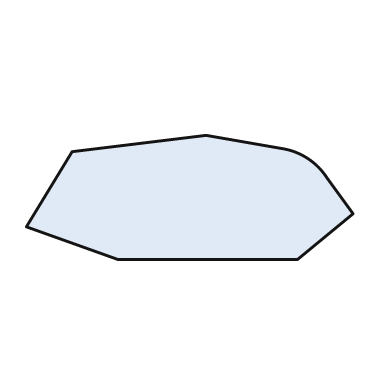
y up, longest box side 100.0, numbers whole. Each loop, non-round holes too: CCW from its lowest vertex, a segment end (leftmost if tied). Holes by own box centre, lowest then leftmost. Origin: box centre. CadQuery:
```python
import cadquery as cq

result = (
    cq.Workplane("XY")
    .moveTo(-22.0, -19.0)
    .lineTo(33.0, -19.0)
    .lineTo(50.0, -5.0)
    .lineTo(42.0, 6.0)
    .threePointArc((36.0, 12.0), (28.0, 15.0))
    .lineTo(5.0, 19.0)
    .lineTo(-36.0, 14.0)
    .lineTo(-50.0, -9.0)
    .close()
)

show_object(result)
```